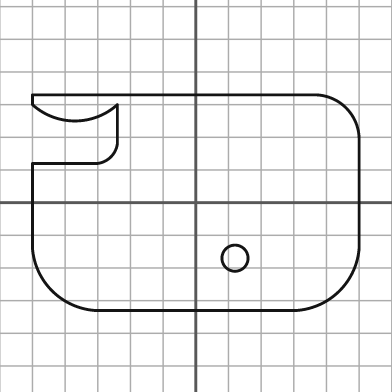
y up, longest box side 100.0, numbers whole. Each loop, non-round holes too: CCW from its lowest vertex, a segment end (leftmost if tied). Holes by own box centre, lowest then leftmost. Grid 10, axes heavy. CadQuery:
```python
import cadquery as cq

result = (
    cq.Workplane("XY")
    .moveTo(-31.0, -33.0)
    .lineTo(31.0, -33.0)
    .threePointArc((44.0, -27.0), (50.0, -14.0))
    .lineTo(50.0, 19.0)
    .threePointArc((46.0, 29.0), (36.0, 33.0))
    .lineTo(-50.0, 33.0)
    .lineTo(-50.0, 30.0)
    .threePointArc((-37.0, 25.0), (-24.0, 30.0))
    .lineTo(-24.0, 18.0)
    .threePointArc((-26.0, 14.0), (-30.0, 12.0))
    .lineTo(-50.0, 12.0)
    .lineTo(-50.0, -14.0)
    .threePointArc((-44.0, -27.0), (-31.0, -33.0))
    .close()
    .moveTo(12.0, -17.0)
    .circle(4.0)
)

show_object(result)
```